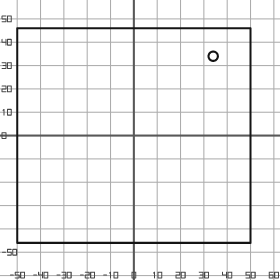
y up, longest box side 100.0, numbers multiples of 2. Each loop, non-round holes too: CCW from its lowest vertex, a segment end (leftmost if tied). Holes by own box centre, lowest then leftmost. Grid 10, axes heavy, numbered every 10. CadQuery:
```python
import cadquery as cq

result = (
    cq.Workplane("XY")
    .moveTo(-50.0, -46.0)
    .lineTo(50.0, -46.0)
    .lineTo(50.0, 46.0)
    .lineTo(-50.0, 46.0)
    .close()
    .moveTo(34.0, 34.0)
    .circle(2.0)
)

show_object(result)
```